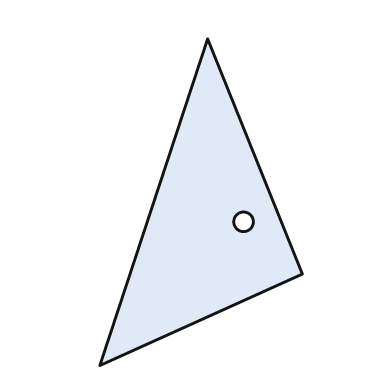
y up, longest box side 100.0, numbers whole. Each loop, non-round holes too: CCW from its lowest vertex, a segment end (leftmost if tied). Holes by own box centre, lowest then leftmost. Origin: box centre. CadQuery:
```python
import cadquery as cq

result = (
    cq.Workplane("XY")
    .moveTo(-31.0, -50.0)
    .lineTo(31.0, -22.0)
    .lineTo(2.0, 50.0)
    .close()
    .moveTo(13.0, -6.0)
    .circle(3.0)
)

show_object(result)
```